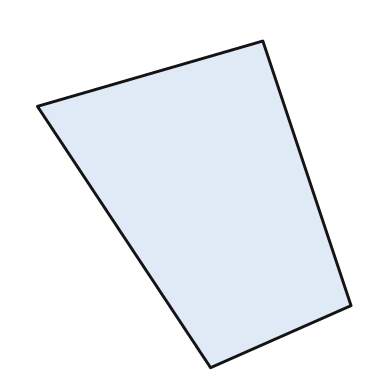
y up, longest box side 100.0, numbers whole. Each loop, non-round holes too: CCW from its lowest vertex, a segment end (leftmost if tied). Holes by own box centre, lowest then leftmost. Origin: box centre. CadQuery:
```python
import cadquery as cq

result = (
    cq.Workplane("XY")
    .moveTo(5.0, -50.0)
    .lineTo(48.0, -31.0)
    .lineTo(21.0, 50.0)
    .lineTo(-48.0, 30.0)
    .close()
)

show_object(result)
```